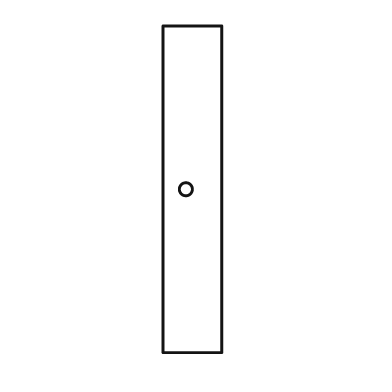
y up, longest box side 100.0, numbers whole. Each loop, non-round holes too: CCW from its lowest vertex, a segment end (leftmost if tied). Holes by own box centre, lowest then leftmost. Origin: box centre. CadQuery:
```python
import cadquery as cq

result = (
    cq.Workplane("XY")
    .moveTo(-9.0, -50.0)
    .lineTo(9.0, -50.0)
    .lineTo(9.0, 50.0)
    .lineTo(-9.0, 50.0)
    .close()
    .moveTo(-2.0, 0.0)
    .circle(2.0)
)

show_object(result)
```